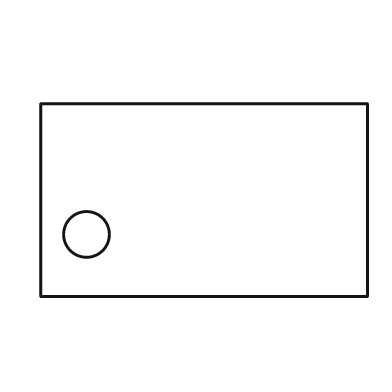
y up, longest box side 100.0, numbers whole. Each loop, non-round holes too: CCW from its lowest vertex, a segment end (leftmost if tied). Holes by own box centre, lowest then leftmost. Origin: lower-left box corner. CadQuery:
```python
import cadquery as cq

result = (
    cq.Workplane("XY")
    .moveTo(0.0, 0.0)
    .lineTo(100.0, 0.0)
    .lineTo(100.0, 59.0)
    .lineTo(0.0, 59.0)
    .close()
    .moveTo(14.0, 19.0)
    .circle(7.0)
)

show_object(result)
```